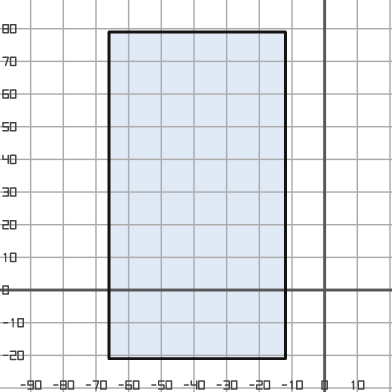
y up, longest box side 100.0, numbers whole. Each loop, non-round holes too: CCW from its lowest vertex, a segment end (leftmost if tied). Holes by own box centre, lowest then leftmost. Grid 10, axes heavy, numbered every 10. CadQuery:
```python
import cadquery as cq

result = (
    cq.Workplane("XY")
    .moveTo(-66.0, -21.0)
    .lineTo(-12.0, -21.0)
    .lineTo(-12.0, 79.0)
    .lineTo(-66.0, 79.0)
    .close()
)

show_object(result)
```